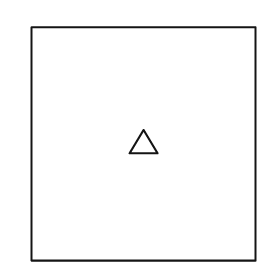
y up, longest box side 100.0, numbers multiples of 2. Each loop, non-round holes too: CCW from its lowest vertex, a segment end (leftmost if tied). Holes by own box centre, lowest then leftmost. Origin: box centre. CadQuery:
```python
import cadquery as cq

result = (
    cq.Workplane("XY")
    .moveTo(-48.0, -50.0)
    .lineTo(48.0, -50.0)
    .lineTo(48.0, 50.0)
    .lineTo(-48.0, 50.0)
    .close()
    .moveTo(-6.0, -4.0)
    .lineTo(6.0, -4.0)
    .lineTo(0.0, 6.0)
    .close()
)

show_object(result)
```